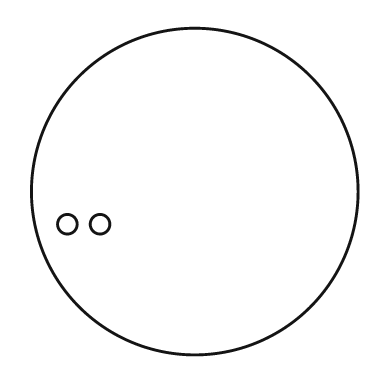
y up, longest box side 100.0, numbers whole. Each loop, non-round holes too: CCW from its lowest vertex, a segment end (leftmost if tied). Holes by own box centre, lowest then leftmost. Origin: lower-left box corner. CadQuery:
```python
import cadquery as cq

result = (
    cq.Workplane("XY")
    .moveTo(50.0, 50.0)
    .circle(50.0)
    .moveTo(11.0, 40.0)
    .circle(3.0)
    .moveTo(21.0, 40.0)
    .circle(3.0)
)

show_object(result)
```